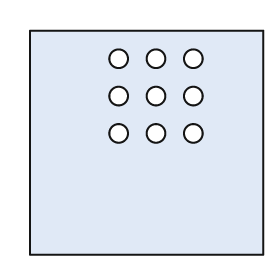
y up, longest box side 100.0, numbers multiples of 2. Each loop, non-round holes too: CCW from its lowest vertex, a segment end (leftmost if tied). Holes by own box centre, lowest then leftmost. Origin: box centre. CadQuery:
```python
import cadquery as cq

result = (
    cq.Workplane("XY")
    .moveTo(-50.0, -48.0)
    .lineTo(50.0, -48.0)
    .lineTo(50.0, 48.0)
    .lineTo(-50.0, 48.0)
    .close()
    .moveTo(-12.0, 4.0)
    .circle(4.0)
    .moveTo(4.0, 4.0)
    .circle(4.0)
    .moveTo(20.0, 4.0)
    .circle(4.0)
    .moveTo(-12.0, 20.0)
    .circle(4.0)
    .moveTo(4.0, 20.0)
    .circle(4.0)
    .moveTo(20.0, 20.0)
    .circle(4.0)
    .moveTo(-12.0, 36.0)
    .circle(4.0)
    .moveTo(4.0, 36.0)
    .circle(4.0)
    .moveTo(20.0, 36.0)
    .circle(4.0)
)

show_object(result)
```